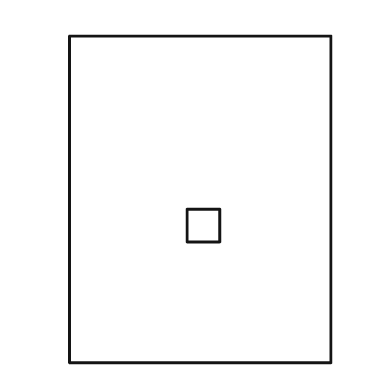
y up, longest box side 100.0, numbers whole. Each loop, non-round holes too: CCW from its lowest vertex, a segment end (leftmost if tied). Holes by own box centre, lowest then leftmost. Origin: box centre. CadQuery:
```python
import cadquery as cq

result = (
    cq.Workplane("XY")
    .moveTo(-40.0, -50.0)
    .lineTo(40.0, -50.0)
    .lineTo(40.0, 50.0)
    .lineTo(-40.0, 50.0)
    .close()
    .moveTo(-4.0, -13.0)
    .lineTo(6.0, -13.0)
    .lineTo(6.0, -3.0)
    .lineTo(-4.0, -3.0)
    .close()
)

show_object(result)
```